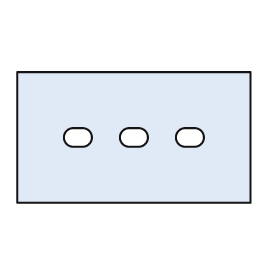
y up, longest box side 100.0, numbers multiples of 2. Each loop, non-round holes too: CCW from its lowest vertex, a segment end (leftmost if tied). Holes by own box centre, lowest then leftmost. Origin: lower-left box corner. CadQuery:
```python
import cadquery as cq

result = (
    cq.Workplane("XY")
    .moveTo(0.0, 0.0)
    .lineTo(100.0, 0.0)
    .lineTo(100.0, 56.0)
    .lineTo(0.0, 56.0)
    .close()
    .moveTo(24.0, 24.0)
    .lineTo(28.0, 24.0)
    .threePointArc((32.0, 28.0), (28.0, 32.0))
    .lineTo(24.0, 32.0)
    .threePointArc((20.0, 28.0), (24.0, 24.0))
    .close()
    .moveTo(48.0, 24.0)
    .lineTo(52.0, 24.0)
    .threePointArc((56.0, 28.0), (52.0, 32.0))
    .lineTo(48.0, 32.0)
    .threePointArc((44.0, 28.0), (48.0, 24.0))
    .close()
    .moveTo(72.0, 24.0)
    .lineTo(76.0, 24.0)
    .threePointArc((80.0, 28.0), (76.0, 32.0))
    .lineTo(72.0, 32.0)
    .threePointArc((68.0, 28.0), (72.0, 24.0))
    .close()
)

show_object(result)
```